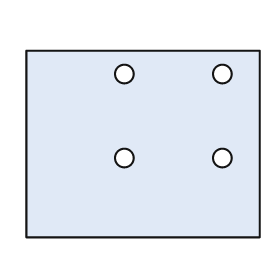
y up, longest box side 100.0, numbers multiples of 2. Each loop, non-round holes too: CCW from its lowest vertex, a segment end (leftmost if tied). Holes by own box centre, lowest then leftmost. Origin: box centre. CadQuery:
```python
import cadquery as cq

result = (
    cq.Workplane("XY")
    .moveTo(-50.0, -40.0)
    .lineTo(50.0, -40.0)
    .lineTo(50.0, 40.0)
    .lineTo(-50.0, 40.0)
    .close()
    .moveTo(-8.0, -6.0)
    .circle(4.0)
    .moveTo(34.0, -6.0)
    .circle(4.0)
    .moveTo(-8.0, 30.0)
    .circle(4.0)
    .moveTo(34.0, 30.0)
    .circle(4.0)
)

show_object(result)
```